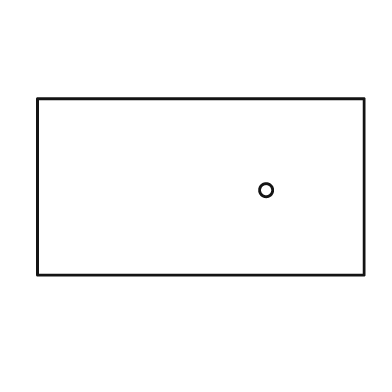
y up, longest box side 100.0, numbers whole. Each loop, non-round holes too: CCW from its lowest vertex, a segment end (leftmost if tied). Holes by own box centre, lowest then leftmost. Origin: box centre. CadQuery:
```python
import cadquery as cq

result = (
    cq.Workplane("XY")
    .moveTo(-50.0, -27.0)
    .lineTo(50.0, -27.0)
    .lineTo(50.0, 27.0)
    .lineTo(-50.0, 27.0)
    .close()
    .moveTo(20.0, -1.0)
    .circle(2.0)
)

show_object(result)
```